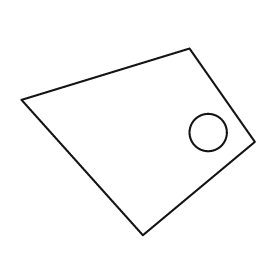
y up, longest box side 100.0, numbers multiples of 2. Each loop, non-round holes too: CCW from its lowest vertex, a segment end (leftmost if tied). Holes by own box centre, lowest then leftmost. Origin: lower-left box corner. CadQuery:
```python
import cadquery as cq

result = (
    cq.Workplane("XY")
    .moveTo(52.0, 0.0)
    .lineTo(100.0, 40.0)
    .lineTo(72.0, 80.0)
    .lineTo(0.0, 58.0)
    .close()
    .moveTo(80.0, 44.0)
    .circle(8.0)
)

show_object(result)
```